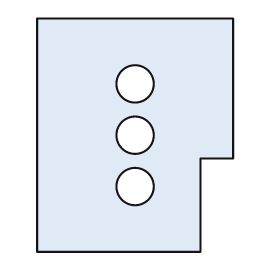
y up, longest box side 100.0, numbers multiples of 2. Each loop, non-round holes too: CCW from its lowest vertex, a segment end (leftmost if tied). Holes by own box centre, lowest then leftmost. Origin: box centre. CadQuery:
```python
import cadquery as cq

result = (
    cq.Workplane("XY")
    .moveTo(-42.0, -50.0)
    .lineTo(28.0, -50.0)
    .lineTo(28.0, -10.0)
    .lineTo(42.0, -10.0)
    .lineTo(42.0, 50.0)
    .lineTo(-42.0, 50.0)
    .close()
    .moveTo(0.0, -22.0)
    .circle(8.0)
    .moveTo(0.0, 0.0)
    .circle(8.0)
    .moveTo(0.0, 22.0)
    .circle(8.0)
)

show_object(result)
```